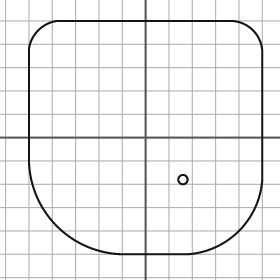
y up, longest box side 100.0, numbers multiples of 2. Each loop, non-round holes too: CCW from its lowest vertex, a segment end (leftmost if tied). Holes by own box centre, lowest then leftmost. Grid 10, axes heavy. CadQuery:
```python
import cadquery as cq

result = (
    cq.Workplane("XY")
    .moveTo(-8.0, -50.0)
    .lineTo(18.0, -50.0)
    .threePointArc((40.0, -40.0), (50.0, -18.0))
    .lineTo(50.0, 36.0)
    .threePointArc((46.0, 46.0), (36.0, 50.0))
    .lineTo(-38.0, 50.0)
    .threePointArc((-46.0, 46.0), (-50.0, 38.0))
    .lineTo(-50.0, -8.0)
    .threePointArc((-38.0, -38.0), (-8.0, -50.0))
    .close()
    .moveTo(16.0, -18.0)
    .circle(2.0)
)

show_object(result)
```